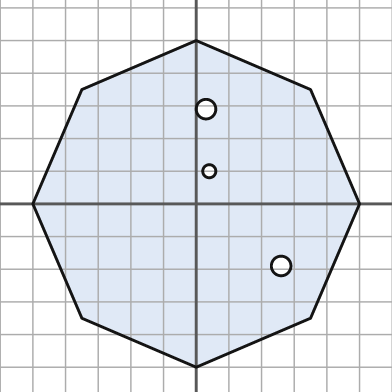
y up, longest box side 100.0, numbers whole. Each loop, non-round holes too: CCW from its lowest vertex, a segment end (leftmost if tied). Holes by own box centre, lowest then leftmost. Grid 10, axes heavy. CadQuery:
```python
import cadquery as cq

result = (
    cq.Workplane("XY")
    .moveTo(0.0, -50.0)
    .lineTo(35.0, -35.0)
    .lineTo(50.0, 0.0)
    .lineTo(35.0, 35.0)
    .lineTo(0.0, 50.0)
    .lineTo(-35.0, 35.0)
    .lineTo(-50.0, 0.0)
    .lineTo(-35.0, -35.0)
    .close()
    .moveTo(26.0, -19.0)
    .circle(3.0)
    .moveTo(4.0, 10.0)
    .circle(2.0)
    .moveTo(3.0, 29.0)
    .circle(3.0)
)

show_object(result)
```